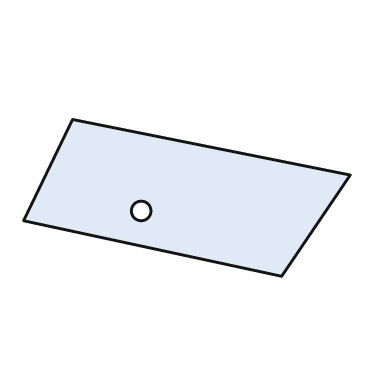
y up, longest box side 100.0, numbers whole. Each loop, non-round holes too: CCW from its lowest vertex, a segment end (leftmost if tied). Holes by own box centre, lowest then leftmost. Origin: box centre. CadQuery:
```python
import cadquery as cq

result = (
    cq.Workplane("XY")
    .moveTo(29.0, -24.0)
    .lineTo(50.0, 7.0)
    .lineTo(-35.0, 24.0)
    .lineTo(-50.0, -7.0)
    .close()
    .moveTo(-14.0, -4.0)
    .circle(3.0)
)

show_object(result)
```